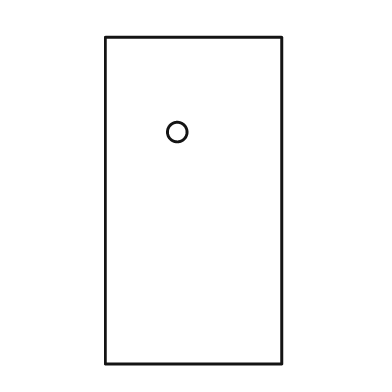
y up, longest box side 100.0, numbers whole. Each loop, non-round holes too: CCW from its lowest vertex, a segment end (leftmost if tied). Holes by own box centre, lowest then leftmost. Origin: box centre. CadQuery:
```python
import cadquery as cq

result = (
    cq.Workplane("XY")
    .moveTo(-27.0, -50.0)
    .lineTo(27.0, -50.0)
    .lineTo(27.0, 50.0)
    .lineTo(-27.0, 50.0)
    .close()
    .moveTo(-5.0, 21.0)
    .circle(3.0)
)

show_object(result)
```